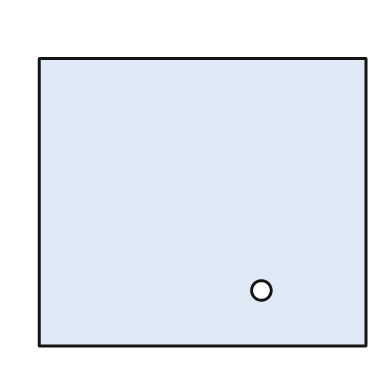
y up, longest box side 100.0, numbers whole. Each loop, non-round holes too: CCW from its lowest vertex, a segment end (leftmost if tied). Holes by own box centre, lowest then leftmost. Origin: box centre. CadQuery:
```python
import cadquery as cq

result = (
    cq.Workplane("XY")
    .moveTo(-50.0, -44.0)
    .lineTo(50.0, -44.0)
    .lineTo(50.0, 44.0)
    .lineTo(-50.0, 44.0)
    .close()
    .moveTo(18.0, -27.0)
    .circle(3.0)
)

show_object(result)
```